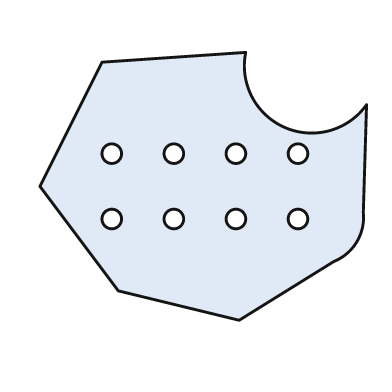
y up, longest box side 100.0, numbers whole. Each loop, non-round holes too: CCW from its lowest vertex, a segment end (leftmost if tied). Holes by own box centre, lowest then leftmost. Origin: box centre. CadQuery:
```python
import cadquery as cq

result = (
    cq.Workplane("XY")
    .moveTo(11.0, -41.0)
    .lineTo(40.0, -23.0)
    .threePointArc((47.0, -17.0), (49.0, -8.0))
    .lineTo(50.0, 25.0)
    .threePointArc((25.0, 18.0), (13.0, 41.0))
    .lineTo(-31.0, 38.0)
    .lineTo(-50.0, 0.0)
    .lineTo(-26.0, -32.0)
    .close()
    .moveTo(-28.0, -10.0)
    .circle(3.0)
    .moveTo(-9.0, -10.0)
    .circle(3.0)
    .moveTo(10.0, -10.0)
    .circle(3.0)
    .moveTo(29.0, -10.0)
    .circle(3.0)
    .moveTo(-28.0, 10.0)
    .circle(3.0)
    .moveTo(-9.0, 10.0)
    .circle(3.0)
    .moveTo(10.0, 10.0)
    .circle(3.0)
    .moveTo(29.0, 10.0)
    .circle(3.0)
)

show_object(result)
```